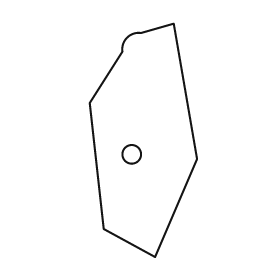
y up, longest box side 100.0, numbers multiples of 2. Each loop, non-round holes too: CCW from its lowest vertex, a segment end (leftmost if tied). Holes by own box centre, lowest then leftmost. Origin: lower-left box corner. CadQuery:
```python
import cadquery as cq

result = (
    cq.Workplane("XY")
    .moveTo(28.0, 0.0)
    .lineTo(46.0, 42.0)
    .lineTo(36.0, 100.0)
    .lineTo(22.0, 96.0)
    .threePointArc((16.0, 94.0), (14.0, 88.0))
    .lineTo(0.0, 66.0)
    .lineTo(6.0, 12.0)
    .close()
    .moveTo(18.0, 44.0)
    .circle(4.0)
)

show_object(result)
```